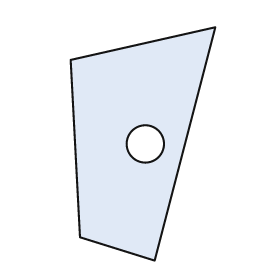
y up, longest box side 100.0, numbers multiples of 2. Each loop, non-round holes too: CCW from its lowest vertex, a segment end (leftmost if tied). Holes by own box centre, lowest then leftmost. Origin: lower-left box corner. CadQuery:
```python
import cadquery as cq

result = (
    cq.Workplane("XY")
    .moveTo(36.0, 0.0)
    .lineTo(62.0, 100.0)
    .lineTo(0.0, 86.0)
    .lineTo(4.0, 10.0)
    .close()
    .moveTo(32.0, 50.0)
    .circle(8.0)
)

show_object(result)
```